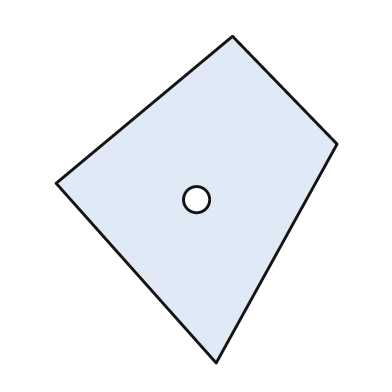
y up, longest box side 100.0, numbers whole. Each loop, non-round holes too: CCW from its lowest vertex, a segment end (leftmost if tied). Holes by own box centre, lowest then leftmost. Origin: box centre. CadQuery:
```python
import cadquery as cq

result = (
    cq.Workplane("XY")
    .moveTo(6.0, -50.0)
    .lineTo(43.0, 17.0)
    .lineTo(11.0, 50.0)
    .lineTo(-43.0, 5.0)
    .close()
    .moveTo(0.0, 0.0)
    .circle(4.0)
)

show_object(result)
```